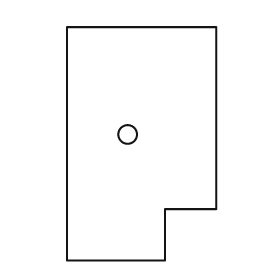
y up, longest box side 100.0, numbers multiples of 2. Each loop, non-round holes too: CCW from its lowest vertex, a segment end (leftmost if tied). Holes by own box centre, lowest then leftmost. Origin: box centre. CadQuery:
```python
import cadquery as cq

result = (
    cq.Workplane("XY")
    .moveTo(-32.0, -50.0)
    .lineTo(10.0, -50.0)
    .lineTo(10.0, -28.0)
    .lineTo(32.0, -28.0)
    .lineTo(32.0, 50.0)
    .lineTo(-32.0, 50.0)
    .close()
    .moveTo(-6.0, 4.0)
    .circle(4.0)
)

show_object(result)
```